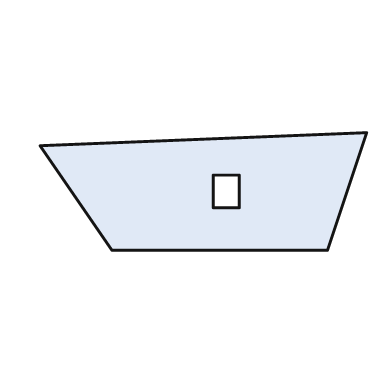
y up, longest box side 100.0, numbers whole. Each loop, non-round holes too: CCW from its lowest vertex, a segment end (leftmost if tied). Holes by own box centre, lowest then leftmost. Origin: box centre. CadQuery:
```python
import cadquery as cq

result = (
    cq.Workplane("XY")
    .moveTo(-28.0, -18.0)
    .lineTo(38.0, -18.0)
    .lineTo(50.0, 18.0)
    .lineTo(-50.0, 14.0)
    .close()
    .moveTo(3.0, -5.0)
    .lineTo(11.0, -5.0)
    .lineTo(11.0, 5.0)
    .lineTo(3.0, 5.0)
    .close()
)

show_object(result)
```